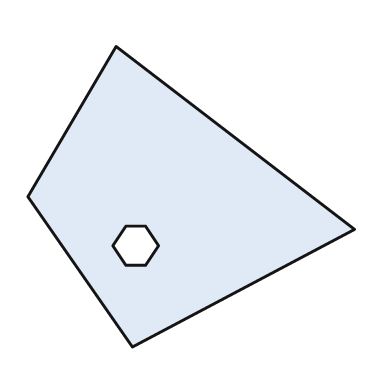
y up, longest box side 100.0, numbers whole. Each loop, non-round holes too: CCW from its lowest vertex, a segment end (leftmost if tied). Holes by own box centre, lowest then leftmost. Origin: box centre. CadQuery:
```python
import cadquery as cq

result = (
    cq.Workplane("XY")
    .moveTo(-18.0, -46.0)
    .lineTo(50.0, -10.0)
    .lineTo(-23.0, 46.0)
    .lineTo(-50.0, 0.0)
    .close()
    .moveTo(-20.0, -21.0)
    .lineTo(-14.0, -21.0)
    .lineTo(-10.0, -15.0)
    .lineTo(-14.0, -9.0)
    .lineTo(-20.0, -9.0)
    .lineTo(-24.0, -15.0)
    .close()
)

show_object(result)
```